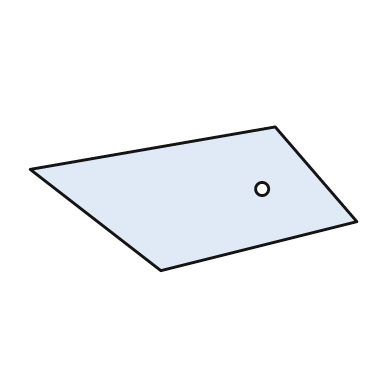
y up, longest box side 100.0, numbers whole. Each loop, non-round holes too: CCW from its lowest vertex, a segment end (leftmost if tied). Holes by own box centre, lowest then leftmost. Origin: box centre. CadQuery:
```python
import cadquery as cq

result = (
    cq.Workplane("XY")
    .moveTo(-10.0, -22.0)
    .lineTo(50.0, -7.0)
    .lineTo(25.0, 22.0)
    .lineTo(-50.0, 9.0)
    .close()
    .moveTo(21.0, 3.0)
    .circle(2.0)
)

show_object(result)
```